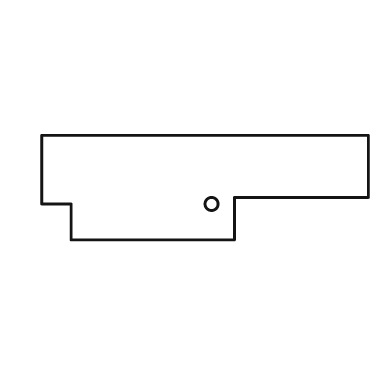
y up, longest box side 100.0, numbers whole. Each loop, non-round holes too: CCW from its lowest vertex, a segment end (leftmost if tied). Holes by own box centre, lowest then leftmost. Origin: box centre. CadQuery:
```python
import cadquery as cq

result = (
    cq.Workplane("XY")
    .moveTo(-41.0, -16.0)
    .lineTo(9.0, -16.0)
    .lineTo(9.0, -3.0)
    .lineTo(50.0, -3.0)
    .lineTo(50.0, 16.0)
    .lineTo(-50.0, 16.0)
    .lineTo(-50.0, -5.0)
    .lineTo(-41.0, -5.0)
    .close()
    .moveTo(2.0, -5.0)
    .circle(2.0)
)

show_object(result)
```